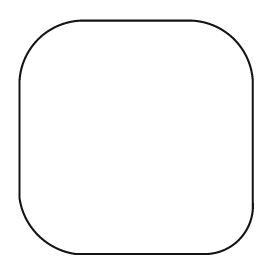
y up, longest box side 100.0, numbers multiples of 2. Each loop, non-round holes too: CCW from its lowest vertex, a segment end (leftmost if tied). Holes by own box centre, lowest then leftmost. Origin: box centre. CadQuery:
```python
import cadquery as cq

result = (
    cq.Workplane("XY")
    .moveTo(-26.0, -50.0)
    .lineTo(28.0, -50.0)
    .threePointArc((44.0, -44.0), (50.0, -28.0))
    .lineTo(50.0, 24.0)
    .threePointArc((42.0, 42.0), (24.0, 50.0))
    .lineTo(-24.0, 50.0)
    .threePointArc((-42.0, 42.0), (-50.0, 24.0))
    .lineTo(-50.0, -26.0)
    .threePointArc((-42.0, -42.0), (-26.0, -50.0))
    .close()
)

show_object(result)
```